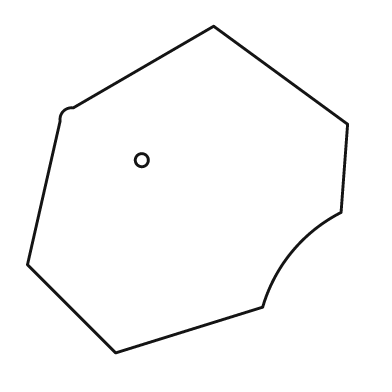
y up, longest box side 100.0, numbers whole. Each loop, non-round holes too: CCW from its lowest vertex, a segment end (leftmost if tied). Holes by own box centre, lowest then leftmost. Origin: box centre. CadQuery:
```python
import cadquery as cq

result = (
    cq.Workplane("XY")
    .moveTo(-22.0, -50.0)
    .lineTo(23.0, -36.0)
    .threePointArc((32.0, -19.0), (47.0, -7.0))
    .lineTo(49.0, 20.0)
    .lineTo(8.0, 50.0)
    .lineTo(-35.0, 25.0)
    .threePointArc((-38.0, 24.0), (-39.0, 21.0))
    .lineTo(-49.0, -23.0)
    .close()
    .moveTo(-14.0, 9.0)
    .circle(2.0)
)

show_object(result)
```